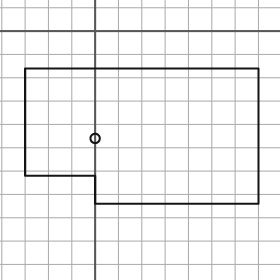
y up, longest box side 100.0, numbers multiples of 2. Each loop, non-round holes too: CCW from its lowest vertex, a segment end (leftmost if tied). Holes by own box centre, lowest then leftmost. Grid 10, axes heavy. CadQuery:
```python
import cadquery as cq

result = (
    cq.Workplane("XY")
    .moveTo(0.0, -74.0)
    .lineTo(70.0, -74.0)
    .lineTo(70.0, -16.0)
    .lineTo(-30.0, -16.0)
    .lineTo(-30.0, -62.0)
    .lineTo(0.0, -62.0)
    .close()
    .moveTo(0.0, -46.0)
    .circle(2.0)
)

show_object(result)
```